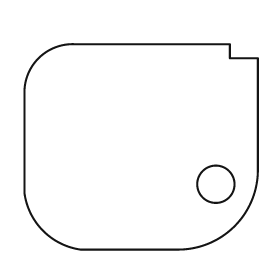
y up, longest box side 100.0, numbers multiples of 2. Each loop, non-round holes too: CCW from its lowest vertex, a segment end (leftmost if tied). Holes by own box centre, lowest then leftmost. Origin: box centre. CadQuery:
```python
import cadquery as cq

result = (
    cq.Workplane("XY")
    .moveTo(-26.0, -44.0)
    .lineTo(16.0, -44.0)
    .threePointArc((40.0, -34.0), (50.0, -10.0))
    .lineTo(50.0, 38.0)
    .lineTo(38.0, 38.0)
    .lineTo(38.0, 44.0)
    .lineTo(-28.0, 44.0)
    .threePointArc((-44.0, 38.0), (-50.0, 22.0))
    .lineTo(-50.0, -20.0)
    .threePointArc((-42.0, -36.0), (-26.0, -44.0))
    .close()
    .moveTo(32.0, -16.0)
    .circle(8.0)
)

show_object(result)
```